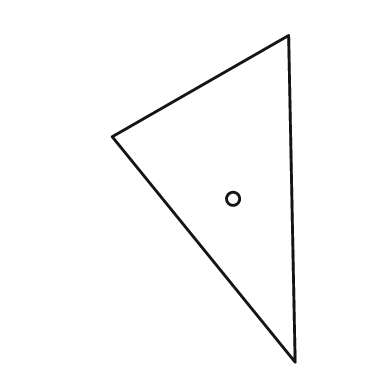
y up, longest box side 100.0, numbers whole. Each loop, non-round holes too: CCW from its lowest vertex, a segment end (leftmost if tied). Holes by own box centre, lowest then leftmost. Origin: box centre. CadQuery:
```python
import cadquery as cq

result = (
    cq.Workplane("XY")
    .moveTo(28.0, -50.0)
    .lineTo(26.0, 50.0)
    .lineTo(-28.0, 19.0)
    .close()
    .moveTo(9.0, 0.0)
    .circle(2.0)
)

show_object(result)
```